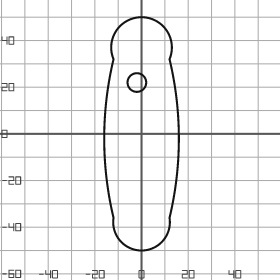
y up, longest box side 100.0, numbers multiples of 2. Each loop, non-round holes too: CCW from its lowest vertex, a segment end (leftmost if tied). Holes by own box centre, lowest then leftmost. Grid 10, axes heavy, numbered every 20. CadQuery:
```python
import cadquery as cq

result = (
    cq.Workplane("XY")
    .moveTo(-12.0, -36.0)
    .threePointArc((0.0, -50.0), (12.0, -36.0))
    .threePointArc((16.0, -2.0), (12.0, 32.0))
    .threePointArc((0.0, 50.0), (-12.0, 32.0))
    .threePointArc((-16.0, -2.0), (-12.0, -36.0))
    .close()
    .moveTo(-2.0, 22.0)
    .circle(4.0)
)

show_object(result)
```